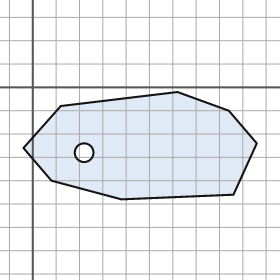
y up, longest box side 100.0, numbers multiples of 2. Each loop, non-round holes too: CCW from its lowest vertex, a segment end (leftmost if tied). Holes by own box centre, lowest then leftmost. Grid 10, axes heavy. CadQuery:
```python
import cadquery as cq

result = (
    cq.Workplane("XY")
    .moveTo(38.0, -48.0)
    .lineTo(86.0, -46.0)
    .lineTo(96.0, -24.0)
    .lineTo(84.0, -10.0)
    .lineTo(62.0, -2.0)
    .lineTo(12.0, -8.0)
    .lineTo(-4.0, -26.0)
    .lineTo(8.0, -40.0)
    .close()
    .moveTo(22.0, -28.0)
    .circle(4.0)
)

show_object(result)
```